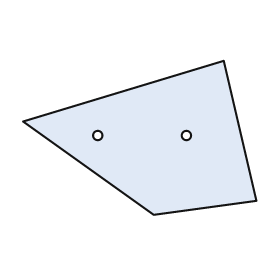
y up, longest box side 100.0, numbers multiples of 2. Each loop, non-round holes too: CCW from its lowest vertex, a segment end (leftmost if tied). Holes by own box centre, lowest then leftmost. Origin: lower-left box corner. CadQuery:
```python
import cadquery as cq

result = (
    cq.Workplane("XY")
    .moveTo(56.0, 0.0)
    .lineTo(100.0, 6.0)
    .lineTo(86.0, 66.0)
    .lineTo(0.0, 40.0)
    .close()
    .moveTo(32.0, 34.0)
    .circle(2.0)
    .moveTo(70.0, 34.0)
    .circle(2.0)
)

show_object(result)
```